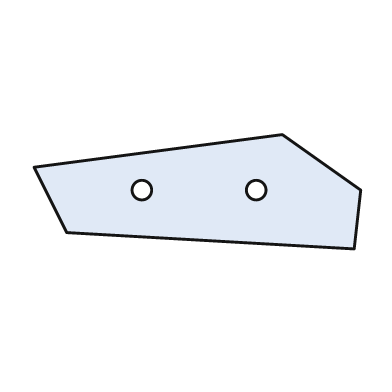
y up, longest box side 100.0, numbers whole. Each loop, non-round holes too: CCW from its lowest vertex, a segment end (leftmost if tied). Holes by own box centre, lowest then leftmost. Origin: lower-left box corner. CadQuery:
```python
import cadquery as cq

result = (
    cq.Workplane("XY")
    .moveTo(98.0, 0.0)
    .lineTo(100.0, 18.0)
    .lineTo(76.0, 35.0)
    .lineTo(0.0, 25.0)
    .lineTo(10.0, 5.0)
    .close()
    .moveTo(33.0, 18.0)
    .circle(3.0)
    .moveTo(68.0, 18.0)
    .circle(3.0)
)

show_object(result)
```